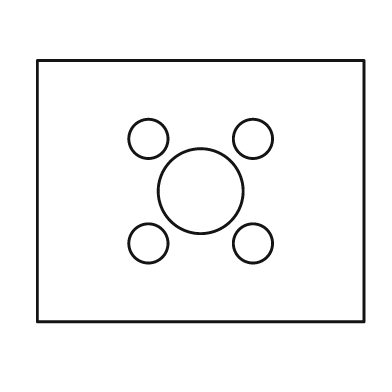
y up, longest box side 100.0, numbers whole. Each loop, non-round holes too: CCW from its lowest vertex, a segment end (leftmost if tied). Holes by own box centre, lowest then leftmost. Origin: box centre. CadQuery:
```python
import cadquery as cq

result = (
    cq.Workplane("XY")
    .moveTo(-50.0, -40.0)
    .lineTo(50.0, -40.0)
    .lineTo(50.0, 40.0)
    .lineTo(-50.0, 40.0)
    .close()
    .moveTo(-16.0, -16.0)
    .circle(6.0)
    .moveTo(16.0, -16.0)
    .circle(6.0)
    .moveTo(0.0, 0.0)
    .circle(13.0)
    .moveTo(-16.0, 16.0)
    .circle(6.0)
    .moveTo(16.0, 16.0)
    .circle(6.0)
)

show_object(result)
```